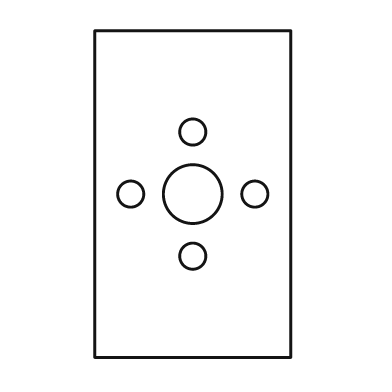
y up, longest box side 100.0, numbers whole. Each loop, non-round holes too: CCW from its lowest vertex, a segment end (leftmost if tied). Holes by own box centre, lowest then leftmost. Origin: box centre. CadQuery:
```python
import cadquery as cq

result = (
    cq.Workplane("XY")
    .moveTo(-30.0, -50.0)
    .lineTo(30.0, -50.0)
    .lineTo(30.0, 50.0)
    .lineTo(-30.0, 50.0)
    .close()
    .moveTo(0.0, -19.0)
    .circle(4.0)
    .moveTo(-19.0, 0.0)
    .circle(4.0)
    .moveTo(0.0, 0.0)
    .circle(9.0)
    .moveTo(19.0, 0.0)
    .circle(4.0)
    .moveTo(0.0, 19.0)
    .circle(4.0)
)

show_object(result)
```